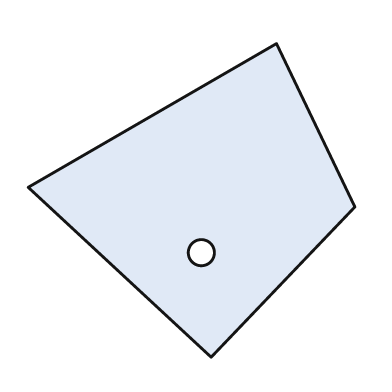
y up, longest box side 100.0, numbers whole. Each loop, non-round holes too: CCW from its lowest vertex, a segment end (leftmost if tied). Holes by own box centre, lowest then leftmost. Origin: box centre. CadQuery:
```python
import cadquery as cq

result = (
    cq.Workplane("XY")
    .moveTo(6.0, -48.0)
    .lineTo(50.0, -2.0)
    .lineTo(26.0, 48.0)
    .lineTo(-50.0, 4.0)
    .close()
    .moveTo(3.0, -16.0)
    .circle(4.0)
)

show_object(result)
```